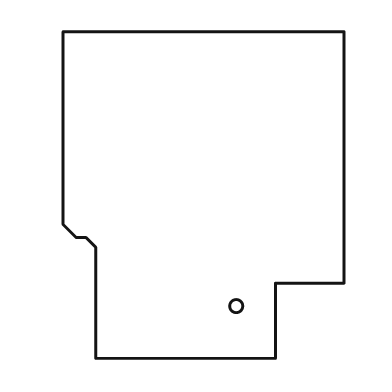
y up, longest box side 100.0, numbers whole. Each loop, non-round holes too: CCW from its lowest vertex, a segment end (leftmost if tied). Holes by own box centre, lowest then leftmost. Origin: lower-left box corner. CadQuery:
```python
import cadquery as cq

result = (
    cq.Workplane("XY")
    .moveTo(10.0, 0.0)
    .lineTo(65.0, 0.0)
    .lineTo(65.0, 23.0)
    .lineTo(86.0, 23.0)
    .lineTo(86.0, 100.0)
    .lineTo(0.0, 100.0)
    .lineTo(0.0, 41.0)
    .lineTo(4.0, 37.0)
    .lineTo(7.0, 37.0)
    .lineTo(10.0, 34.0)
    .close()
    .moveTo(53.0, 16.0)
    .circle(2.0)
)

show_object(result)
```